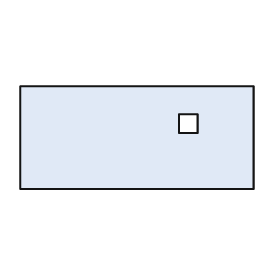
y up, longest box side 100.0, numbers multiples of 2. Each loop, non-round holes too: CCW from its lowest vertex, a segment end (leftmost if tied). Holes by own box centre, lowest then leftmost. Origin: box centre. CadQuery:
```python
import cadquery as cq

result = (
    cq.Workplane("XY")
    .moveTo(-50.0, -22.0)
    .lineTo(50.0, -22.0)
    .lineTo(50.0, 22.0)
    .lineTo(-50.0, 22.0)
    .close()
    .moveTo(18.0, 2.0)
    .lineTo(26.0, 2.0)
    .lineTo(26.0, 10.0)
    .lineTo(18.0, 10.0)
    .close()
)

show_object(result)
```